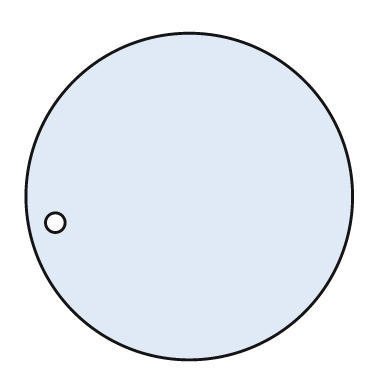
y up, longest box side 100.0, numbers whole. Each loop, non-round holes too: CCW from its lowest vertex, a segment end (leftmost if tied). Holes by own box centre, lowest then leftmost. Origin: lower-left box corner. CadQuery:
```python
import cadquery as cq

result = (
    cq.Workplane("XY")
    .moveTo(50.0, 50.0)
    .circle(50.0)
    .moveTo(9.0, 42.0)
    .circle(3.0)
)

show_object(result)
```